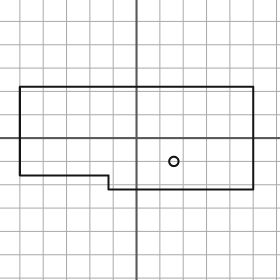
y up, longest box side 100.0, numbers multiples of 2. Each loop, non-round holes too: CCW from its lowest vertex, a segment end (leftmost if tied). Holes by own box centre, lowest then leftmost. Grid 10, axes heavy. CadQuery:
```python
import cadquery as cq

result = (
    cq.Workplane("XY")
    .moveTo(-12.0, -22.0)
    .lineTo(50.0, -22.0)
    .lineTo(50.0, 22.0)
    .lineTo(-50.0, 22.0)
    .lineTo(-50.0, -16.0)
    .lineTo(-12.0, -16.0)
    .close()
    .moveTo(16.0, -10.0)
    .circle(2.0)
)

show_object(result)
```